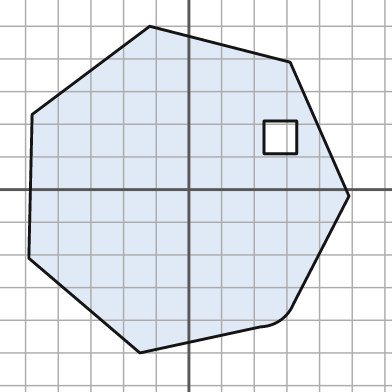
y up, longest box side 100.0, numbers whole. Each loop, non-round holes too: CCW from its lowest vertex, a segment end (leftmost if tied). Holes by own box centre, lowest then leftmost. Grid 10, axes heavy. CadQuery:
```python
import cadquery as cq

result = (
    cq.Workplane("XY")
    .moveTo(-15.0, -50.0)
    .lineTo(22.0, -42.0)
    .threePointArc((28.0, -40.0), (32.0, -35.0))
    .lineTo(49.0, -2.0)
    .lineTo(31.0, 39.0)
    .lineTo(-12.0, 50.0)
    .lineTo(-48.0, 23.0)
    .lineTo(-49.0, -21.0)
    .close()
    .moveTo(23.0, 11.0)
    .lineTo(33.0, 11.0)
    .lineTo(33.0, 21.0)
    .lineTo(23.0, 21.0)
    .close()
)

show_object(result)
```